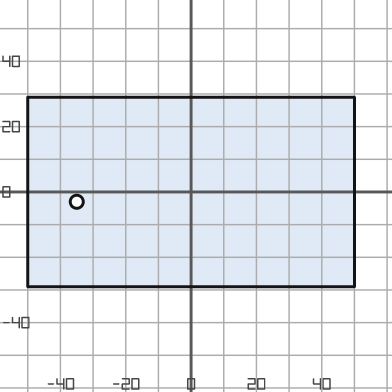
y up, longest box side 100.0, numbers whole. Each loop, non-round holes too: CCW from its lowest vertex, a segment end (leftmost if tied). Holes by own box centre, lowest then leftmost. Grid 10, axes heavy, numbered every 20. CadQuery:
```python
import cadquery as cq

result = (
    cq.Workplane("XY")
    .moveTo(-50.0, -29.0)
    .lineTo(50.0, -29.0)
    .lineTo(50.0, 29.0)
    .lineTo(-50.0, 29.0)
    .close()
    .moveTo(-35.0, -3.0)
    .circle(2.0)
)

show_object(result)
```